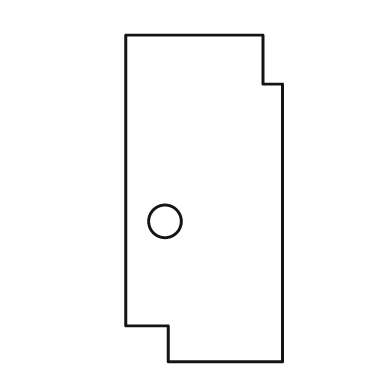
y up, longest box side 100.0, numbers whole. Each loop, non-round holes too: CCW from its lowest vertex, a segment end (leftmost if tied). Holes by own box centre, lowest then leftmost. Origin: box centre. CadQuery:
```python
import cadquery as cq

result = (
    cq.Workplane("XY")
    .moveTo(-11.0, -50.0)
    .lineTo(24.0, -50.0)
    .lineTo(24.0, 35.0)
    .lineTo(18.0, 35.0)
    .lineTo(18.0, 50.0)
    .lineTo(-24.0, 50.0)
    .lineTo(-24.0, -39.0)
    .lineTo(-11.0, -39.0)
    .close()
    .moveTo(-12.0, -7.0)
    .circle(5.0)
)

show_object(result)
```